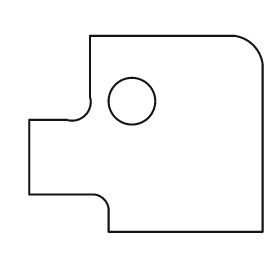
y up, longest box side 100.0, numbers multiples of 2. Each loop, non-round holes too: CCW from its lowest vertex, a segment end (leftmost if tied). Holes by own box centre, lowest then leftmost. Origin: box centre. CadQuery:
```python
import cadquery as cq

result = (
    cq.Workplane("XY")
    .moveTo(-16.0, -42.0)
    .lineTo(50.0, -42.0)
    .lineTo(50.0, 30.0)
    .threePointArc((46.0, 38.0), (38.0, 42.0))
    .lineTo(-24.0, 42.0)
    .lineTo(-24.0, 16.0)
    .threePointArc((-26.0, 8.0), (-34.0, 6.0))
    .lineTo(-50.0, 6.0)
    .lineTo(-50.0, -26.0)
    .lineTo(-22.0, -26.0)
    .threePointArc((-18.0, -28.0), (-16.0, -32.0))
    .close()
    .moveTo(-6.0, 14.0)
    .circle(10.0)
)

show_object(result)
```